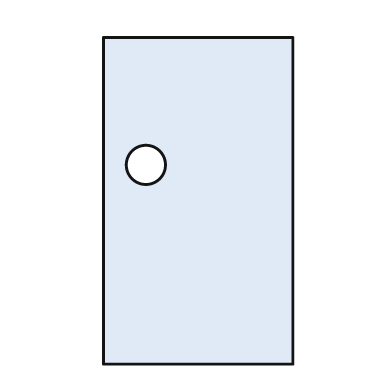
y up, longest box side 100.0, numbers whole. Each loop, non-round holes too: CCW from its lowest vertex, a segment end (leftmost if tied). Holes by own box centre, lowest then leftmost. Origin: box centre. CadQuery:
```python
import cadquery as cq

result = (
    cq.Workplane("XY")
    .moveTo(-29.0, -50.0)
    .lineTo(29.0, -50.0)
    .lineTo(29.0, 50.0)
    .lineTo(-29.0, 50.0)
    .close()
    .moveTo(-16.0, 11.0)
    .circle(6.0)
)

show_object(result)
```